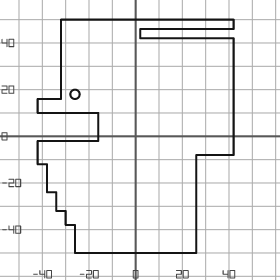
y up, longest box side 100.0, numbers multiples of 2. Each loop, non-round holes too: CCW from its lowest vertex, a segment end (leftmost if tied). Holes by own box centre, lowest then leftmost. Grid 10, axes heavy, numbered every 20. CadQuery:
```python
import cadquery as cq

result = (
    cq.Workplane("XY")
    .moveTo(-26.0, -50.0)
    .lineTo(26.0, -50.0)
    .lineTo(26.0, -8.0)
    .lineTo(42.0, -8.0)
    .lineTo(42.0, 42.0)
    .lineTo(2.0, 42.0)
    .lineTo(2.0, 46.0)
    .lineTo(42.0, 46.0)
    .lineTo(42.0, 50.0)
    .lineTo(-32.0, 50.0)
    .lineTo(-32.0, 16.0)
    .lineTo(-42.0, 16.0)
    .lineTo(-42.0, 10.0)
    .lineTo(-16.0, 10.0)
    .lineTo(-16.0, -2.0)
    .lineTo(-42.0, -2.0)
    .lineTo(-42.0, -12.0)
    .lineTo(-38.0, -12.0)
    .lineTo(-38.0, -24.0)
    .lineTo(-34.0, -24.0)
    .lineTo(-34.0, -32.0)
    .lineTo(-30.0, -32.0)
    .lineTo(-30.0, -38.0)
    .lineTo(-26.0, -38.0)
    .close()
    .moveTo(-26.0, 18.0)
    .circle(2.0)
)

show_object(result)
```